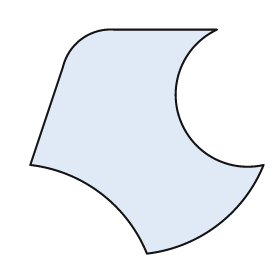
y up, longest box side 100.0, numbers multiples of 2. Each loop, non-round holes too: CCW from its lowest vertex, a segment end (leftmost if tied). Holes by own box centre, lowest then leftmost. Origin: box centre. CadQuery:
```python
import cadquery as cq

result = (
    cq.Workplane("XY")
    .moveTo(0.0, -48.0)
    .threePointArc((30.0, -36.0), (50.0, -10.0))
    .threePointArc((14.0, 10.0), (30.0, 48.0))
    .lineTo(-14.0, 48.0)
    .threePointArc((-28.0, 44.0), (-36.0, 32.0))
    .lineTo(-50.0, -10.0)
    .threePointArc((-20.0, -22.0), (0.0, -48.0))
    .close()
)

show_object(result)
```